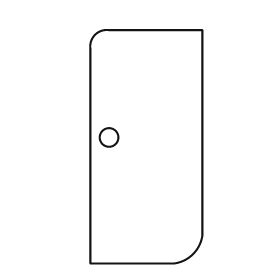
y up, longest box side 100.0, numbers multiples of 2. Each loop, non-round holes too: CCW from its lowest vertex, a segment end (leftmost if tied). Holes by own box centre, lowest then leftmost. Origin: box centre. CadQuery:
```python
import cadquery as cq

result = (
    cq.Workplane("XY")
    .moveTo(-24.0, -50.0)
    .lineTo(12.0, -50.0)
    .threePointArc((20.0, -46.0), (24.0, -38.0))
    .lineTo(24.0, 50.0)
    .lineTo(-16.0, 50.0)
    .threePointArc((-22.0, 48.0), (-24.0, 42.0))
    .close()
    .moveTo(-16.0, 4.0)
    .circle(4.0)
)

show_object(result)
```